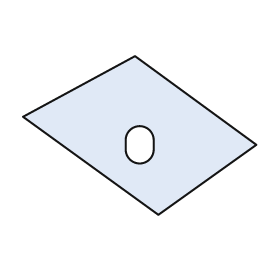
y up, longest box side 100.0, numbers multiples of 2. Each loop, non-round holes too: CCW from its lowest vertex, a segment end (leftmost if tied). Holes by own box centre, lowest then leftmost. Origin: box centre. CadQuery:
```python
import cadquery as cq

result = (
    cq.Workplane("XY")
    .moveTo(8.0, -34.0)
    .lineTo(50.0, -4.0)
    .lineTo(-2.0, 34.0)
    .lineTo(-50.0, 8.0)
    .close()
    .moveTo(-6.0, -6.0)
    .threePointArc((0.0, -12.0), (6.0, -6.0))
    .lineTo(6.0, -2.0)
    .threePointArc((0.0, 4.0), (-6.0, -2.0))
    .close()
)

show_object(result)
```